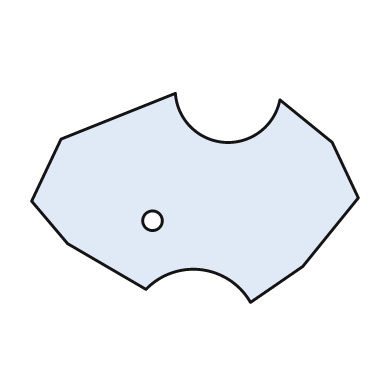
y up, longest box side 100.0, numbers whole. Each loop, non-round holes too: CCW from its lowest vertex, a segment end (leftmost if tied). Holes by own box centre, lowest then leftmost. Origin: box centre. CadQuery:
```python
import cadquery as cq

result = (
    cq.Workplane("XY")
    .moveTo(17.0, -32.0)
    .lineTo(33.0, -21.0)
    .lineTo(50.0, 0.0)
    .lineTo(42.0, 17.0)
    .lineTo(26.0, 30.0)
    .threePointArc((9.0, 17.0), (-6.0, 32.0))
    .lineTo(-41.0, 18.0)
    .lineTo(-50.0, -1.0)
    .lineTo(-39.0, -14.0)
    .lineTo(-15.0, -28.0)
    .threePointArc((2.0, -22.0), (17.0, -32.0))
    .close()
    .moveTo(-13.0, -7.0)
    .circle(3.0)
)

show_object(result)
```